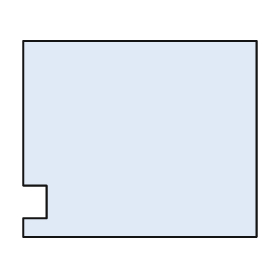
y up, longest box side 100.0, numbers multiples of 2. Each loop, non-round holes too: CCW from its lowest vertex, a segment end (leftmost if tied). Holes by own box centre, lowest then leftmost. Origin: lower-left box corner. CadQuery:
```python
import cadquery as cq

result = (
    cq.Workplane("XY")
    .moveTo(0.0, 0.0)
    .lineTo(100.0, 0.0)
    .lineTo(100.0, 84.0)
    .lineTo(0.0, 84.0)
    .lineTo(0.0, 22.0)
    .lineTo(10.0, 22.0)
    .lineTo(10.0, 8.0)
    .lineTo(0.0, 8.0)
    .close()
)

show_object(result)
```